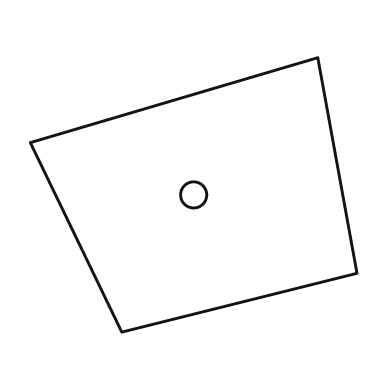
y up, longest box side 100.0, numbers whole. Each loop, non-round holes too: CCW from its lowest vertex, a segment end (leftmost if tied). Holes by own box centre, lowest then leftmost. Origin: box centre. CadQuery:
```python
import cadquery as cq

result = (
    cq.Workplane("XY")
    .moveTo(-22.0, -42.0)
    .lineTo(50.0, -24.0)
    .lineTo(38.0, 42.0)
    .lineTo(-50.0, 16.0)
    .close()
    .moveTo(0.0, 0.0)
    .circle(4.0)
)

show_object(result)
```